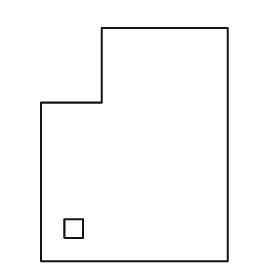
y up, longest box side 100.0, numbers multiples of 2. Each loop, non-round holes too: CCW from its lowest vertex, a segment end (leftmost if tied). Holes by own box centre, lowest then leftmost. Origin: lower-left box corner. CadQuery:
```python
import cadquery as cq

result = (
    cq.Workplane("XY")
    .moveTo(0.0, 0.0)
    .lineTo(80.0, 0.0)
    .lineTo(80.0, 100.0)
    .lineTo(26.0, 100.0)
    .lineTo(26.0, 68.0)
    .lineTo(0.0, 68.0)
    .close()
    .moveTo(10.0, 10.0)
    .lineTo(18.0, 10.0)
    .lineTo(18.0, 18.0)
    .lineTo(10.0, 18.0)
    .close()
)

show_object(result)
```